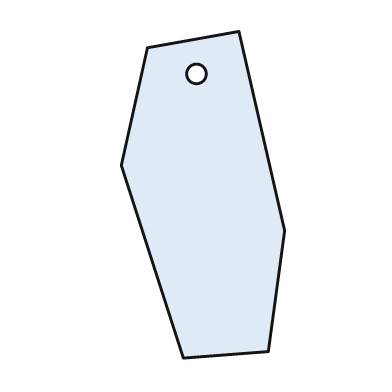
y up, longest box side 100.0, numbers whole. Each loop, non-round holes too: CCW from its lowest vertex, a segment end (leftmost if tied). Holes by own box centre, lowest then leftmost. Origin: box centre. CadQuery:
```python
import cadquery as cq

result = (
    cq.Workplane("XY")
    .moveTo(-6.0, -50.0)
    .lineTo(20.0, -48.0)
    .lineTo(25.0, -11.0)
    .lineTo(11.0, 50.0)
    .lineTo(-17.0, 45.0)
    .lineTo(-25.0, 9.0)
    .close()
    .moveTo(-2.0, 37.0)
    .circle(3.0)
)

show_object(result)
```